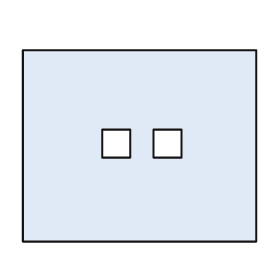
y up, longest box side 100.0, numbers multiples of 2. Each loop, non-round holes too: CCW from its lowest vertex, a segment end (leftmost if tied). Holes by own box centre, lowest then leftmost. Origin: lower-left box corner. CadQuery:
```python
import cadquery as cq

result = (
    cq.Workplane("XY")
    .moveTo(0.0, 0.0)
    .lineTo(100.0, 0.0)
    .lineTo(100.0, 82.0)
    .lineTo(0.0, 82.0)
    .close()
    .moveTo(34.0, 36.0)
    .lineTo(46.0, 36.0)
    .lineTo(46.0, 48.0)
    .lineTo(34.0, 48.0)
    .close()
    .moveTo(56.0, 36.0)
    .lineTo(68.0, 36.0)
    .lineTo(68.0, 48.0)
    .lineTo(56.0, 48.0)
    .close()
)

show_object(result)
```